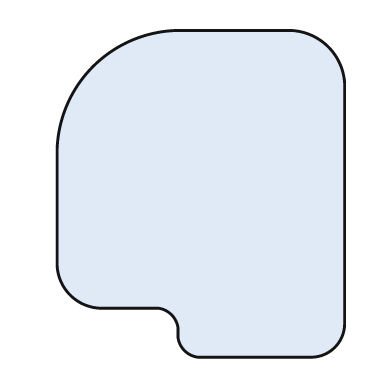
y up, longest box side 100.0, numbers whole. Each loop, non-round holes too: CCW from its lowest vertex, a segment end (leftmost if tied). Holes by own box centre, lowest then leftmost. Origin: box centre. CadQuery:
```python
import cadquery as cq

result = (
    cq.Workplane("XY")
    .moveTo(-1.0, -50.0)
    .lineTo(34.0, -50.0)
    .threePointArc((41.0, -47.0), (44.0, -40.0))
    .lineTo(44.0, 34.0)
    .threePointArc((39.0, 45.0), (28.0, 50.0))
    .lineTo(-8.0, 50.0)
    .threePointArc((-33.0, 39.0), (-44.0, 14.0))
    .lineTo(-44.0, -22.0)
    .threePointArc((-40.0, -31.0), (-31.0, -35.0))
    .lineTo(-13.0, -35.0)
    .threePointArc((-9.0, -37.0), (-7.0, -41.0))
    .lineTo(-7.0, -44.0)
    .threePointArc((-5.0, -48.0), (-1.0, -50.0))
    .close()
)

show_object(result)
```